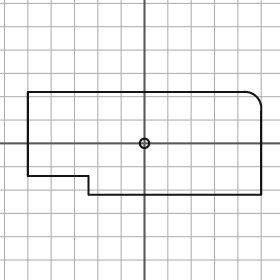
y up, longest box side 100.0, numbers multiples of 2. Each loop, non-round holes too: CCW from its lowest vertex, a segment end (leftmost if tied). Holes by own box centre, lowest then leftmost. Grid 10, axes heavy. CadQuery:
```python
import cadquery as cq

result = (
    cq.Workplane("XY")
    .moveTo(-24.0, -22.0)
    .lineTo(50.0, -22.0)
    .lineTo(50.0, 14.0)
    .threePointArc((48.0, 20.0), (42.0, 22.0))
    .lineTo(-50.0, 22.0)
    .lineTo(-50.0, -14.0)
    .lineTo(-24.0, -14.0)
    .close()
    .moveTo(0.0, 0.0)
    .circle(2.0)
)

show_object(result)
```